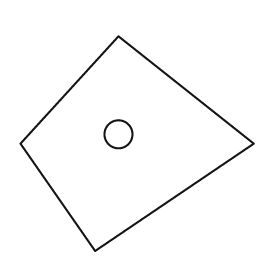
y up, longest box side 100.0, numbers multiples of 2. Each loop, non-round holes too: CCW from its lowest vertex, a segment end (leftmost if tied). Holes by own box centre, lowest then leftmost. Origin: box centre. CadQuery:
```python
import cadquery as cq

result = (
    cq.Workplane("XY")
    .moveTo(-18.0, -46.0)
    .lineTo(50.0, 0.0)
    .lineTo(-8.0, 46.0)
    .lineTo(-50.0, 0.0)
    .close()
    .moveTo(-8.0, 4.0)
    .circle(6.0)
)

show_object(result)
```